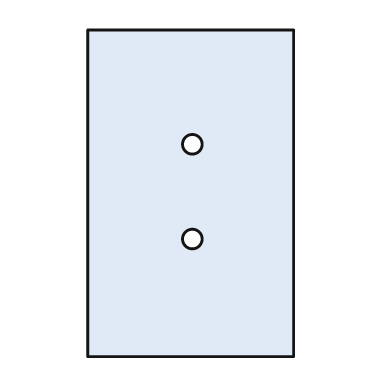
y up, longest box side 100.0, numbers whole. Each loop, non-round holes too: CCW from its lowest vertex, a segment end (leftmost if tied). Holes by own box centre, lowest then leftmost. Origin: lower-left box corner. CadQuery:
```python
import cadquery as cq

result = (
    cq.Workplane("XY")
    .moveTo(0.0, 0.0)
    .lineTo(63.0, 0.0)
    .lineTo(63.0, 100.0)
    .lineTo(0.0, 100.0)
    .close()
    .moveTo(32.0, 36.0)
    .circle(3.0)
    .moveTo(32.0, 65.0)
    .circle(3.0)
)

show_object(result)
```